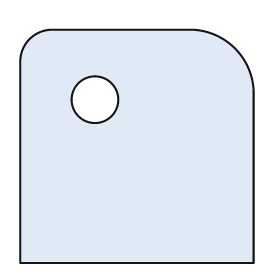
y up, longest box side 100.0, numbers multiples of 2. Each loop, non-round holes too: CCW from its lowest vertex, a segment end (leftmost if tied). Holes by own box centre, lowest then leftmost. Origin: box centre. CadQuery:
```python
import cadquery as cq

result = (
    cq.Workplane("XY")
    .moveTo(-50.0, -50.0)
    .lineTo(50.0, -50.0)
    .lineTo(50.0, 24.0)
    .threePointArc((42.0, 42.0), (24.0, 50.0))
    .lineTo(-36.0, 50.0)
    .threePointArc((-46.0, 46.0), (-50.0, 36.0))
    .close()
    .moveTo(-18.0, 20.0)
    .circle(10.0)
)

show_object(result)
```